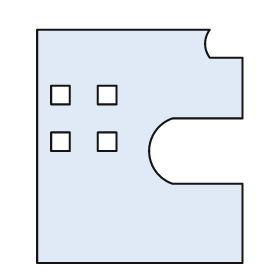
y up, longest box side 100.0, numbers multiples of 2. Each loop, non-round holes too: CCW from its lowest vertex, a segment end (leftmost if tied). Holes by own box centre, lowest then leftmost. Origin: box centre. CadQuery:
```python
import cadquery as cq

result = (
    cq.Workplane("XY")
    .moveTo(-44.0, -50.0)
    .lineTo(44.0, -50.0)
    .lineTo(44.0, -16.0)
    .lineTo(14.0, -16.0)
    .threePointArc((4.0, -2.0), (14.0, 12.0))
    .lineTo(44.0, 12.0)
    .lineTo(44.0, 38.0)
    .lineTo(30.0, 38.0)
    .threePointArc((28.0, 44.0), (30.0, 50.0))
    .lineTo(-44.0, 50.0)
    .close()
    .moveTo(-38.0, -2.0)
    .lineTo(-30.0, -2.0)
    .lineTo(-30.0, 6.0)
    .lineTo(-38.0, 6.0)
    .close()
    .moveTo(-18.0, -2.0)
    .lineTo(-10.0, -2.0)
    .lineTo(-10.0, 6.0)
    .lineTo(-18.0, 6.0)
    .close()
    .moveTo(-38.0, 18.0)
    .lineTo(-30.0, 18.0)
    .lineTo(-30.0, 26.0)
    .lineTo(-38.0, 26.0)
    .close()
    .moveTo(-18.0, 18.0)
    .lineTo(-10.0, 18.0)
    .lineTo(-10.0, 26.0)
    .lineTo(-18.0, 26.0)
    .close()
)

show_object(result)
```